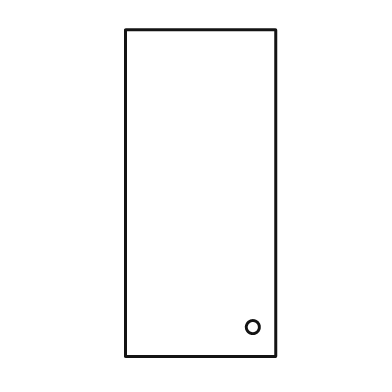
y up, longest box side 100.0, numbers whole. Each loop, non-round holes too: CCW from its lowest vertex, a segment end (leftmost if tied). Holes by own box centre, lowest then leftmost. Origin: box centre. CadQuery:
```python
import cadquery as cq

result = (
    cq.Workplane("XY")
    .moveTo(-23.0, -50.0)
    .lineTo(23.0, -50.0)
    .lineTo(23.0, 50.0)
    .lineTo(-23.0, 50.0)
    .close()
    .moveTo(16.0, -41.0)
    .circle(2.0)
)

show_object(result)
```